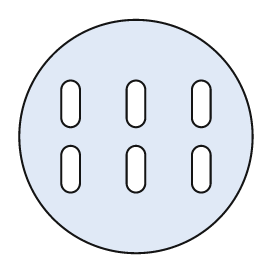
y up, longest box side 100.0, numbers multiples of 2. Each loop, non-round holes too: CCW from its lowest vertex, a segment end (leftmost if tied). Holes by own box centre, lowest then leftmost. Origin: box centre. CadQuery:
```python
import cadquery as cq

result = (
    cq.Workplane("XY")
    .moveTo(0.0, 0.0)
    .circle(50.0)
    .moveTo(-32.0, -20.0)
    .threePointArc((-28.0, -24.0), (-24.0, -20.0))
    .lineTo(-24.0, -8.0)
    .threePointArc((-28.0, -4.0), (-32.0, -8.0))
    .close()
    .moveTo(-4.0, -20.0)
    .threePointArc((0.0, -24.0), (4.0, -20.0))
    .lineTo(4.0, -8.0)
    .threePointArc((0.0, -4.0), (-4.0, -8.0))
    .close()
    .moveTo(24.0, -20.0)
    .threePointArc((28.0, -24.0), (32.0, -20.0))
    .lineTo(32.0, -8.0)
    .threePointArc((28.0, -4.0), (24.0, -8.0))
    .close()
    .moveTo(-32.0, 8.0)
    .threePointArc((-28.0, 4.0), (-24.0, 8.0))
    .lineTo(-24.0, 20.0)
    .threePointArc((-28.0, 24.0), (-32.0, 20.0))
    .close()
    .moveTo(-4.0, 8.0)
    .threePointArc((0.0, 4.0), (4.0, 8.0))
    .lineTo(4.0, 20.0)
    .threePointArc((0.0, 24.0), (-4.0, 20.0))
    .close()
    .moveTo(24.0, 8.0)
    .threePointArc((28.0, 4.0), (32.0, 8.0))
    .lineTo(32.0, 20.0)
    .threePointArc((28.0, 24.0), (24.0, 20.0))
    .close()
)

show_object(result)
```